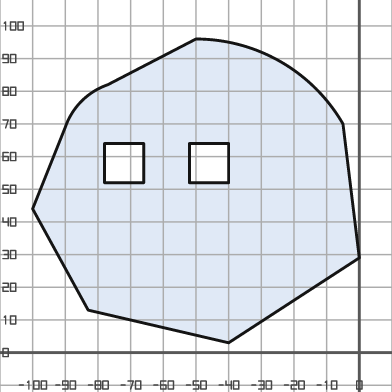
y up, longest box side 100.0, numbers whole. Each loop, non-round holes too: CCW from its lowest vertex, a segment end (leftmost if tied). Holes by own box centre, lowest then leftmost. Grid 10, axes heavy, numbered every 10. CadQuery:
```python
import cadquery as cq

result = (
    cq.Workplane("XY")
    .moveTo(-40.0, 3.0)
    .lineTo(0.0, 29.0)
    .lineTo(-5.0, 70.0)
    .threePointArc((-24.0, 89.0), (-50.0, 96.0))
    .lineTo(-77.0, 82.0)
    .threePointArc((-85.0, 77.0), (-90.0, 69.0))
    .lineTo(-100.0, 44.0)
    .lineTo(-83.0, 13.0)
    .close()
    .moveTo(-78.0, 52.0)
    .lineTo(-66.0, 52.0)
    .lineTo(-66.0, 64.0)
    .lineTo(-78.0, 64.0)
    .close()
    .moveTo(-52.0, 52.0)
    .lineTo(-40.0, 52.0)
    .lineTo(-40.0, 64.0)
    .lineTo(-52.0, 64.0)
    .close()
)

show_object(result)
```